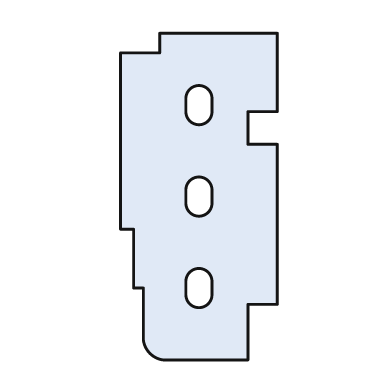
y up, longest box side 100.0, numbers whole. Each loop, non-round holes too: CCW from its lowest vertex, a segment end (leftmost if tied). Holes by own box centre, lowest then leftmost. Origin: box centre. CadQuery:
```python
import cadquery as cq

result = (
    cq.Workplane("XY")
    .moveTo(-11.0, -50.0)
    .lineTo(15.0, -50.0)
    .lineTo(15.0, -33.0)
    .lineTo(24.0, -33.0)
    .lineTo(24.0, 16.0)
    .lineTo(15.0, 16.0)
    .lineTo(15.0, 26.0)
    .lineTo(24.0, 26.0)
    .lineTo(24.0, 50.0)
    .lineTo(-12.0, 50.0)
    .lineTo(-12.0, 44.0)
    .lineTo(-24.0, 44.0)
    .lineTo(-24.0, -10.0)
    .lineTo(-20.0, -10.0)
    .lineTo(-20.0, -28.0)
    .lineTo(-17.0, -28.0)
    .lineTo(-17.0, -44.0)
    .threePointArc((-15.0, -48.0), (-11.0, -50.0))
    .close()
    .moveTo(-4.0, -30.0)
    .threePointArc((0.0, -34.0), (4.0, -30.0))
    .lineTo(4.0, -26.0)
    .threePointArc((0.0, -22.0), (-4.0, -26.0))
    .close()
    .moveTo(-4.0, -2.0)
    .threePointArc((0.0, -6.0), (4.0, -2.0))
    .lineTo(4.0, 2.0)
    .threePointArc((0.0, 6.0), (-4.0, 2.0))
    .close()
    .moveTo(-4.0, 26.0)
    .threePointArc((0.0, 22.0), (4.0, 26.0))
    .lineTo(4.0, 30.0)
    .threePointArc((0.0, 34.0), (-4.0, 30.0))
    .close()
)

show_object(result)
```